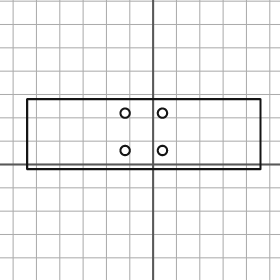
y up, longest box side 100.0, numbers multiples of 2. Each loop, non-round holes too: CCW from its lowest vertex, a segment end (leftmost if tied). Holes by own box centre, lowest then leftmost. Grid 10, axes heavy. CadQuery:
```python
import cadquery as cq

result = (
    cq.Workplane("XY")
    .moveTo(-54.0, -2.0)
    .lineTo(46.0, -2.0)
    .lineTo(46.0, 28.0)
    .lineTo(-54.0, 28.0)
    .close()
    .moveTo(-12.0, 6.0)
    .circle(2.0)
    .moveTo(4.0, 6.0)
    .circle(2.0)
    .moveTo(-12.0, 22.0)
    .circle(2.0)
    .moveTo(4.0, 22.0)
    .circle(2.0)
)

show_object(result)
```